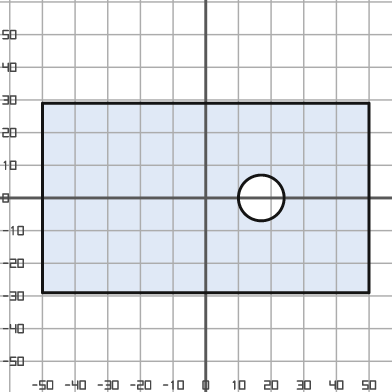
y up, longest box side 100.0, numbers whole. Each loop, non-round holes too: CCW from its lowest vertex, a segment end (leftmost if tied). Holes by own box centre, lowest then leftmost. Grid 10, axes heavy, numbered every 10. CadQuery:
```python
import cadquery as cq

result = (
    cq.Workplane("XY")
    .moveTo(-50.0, -29.0)
    .lineTo(50.0, -29.0)
    .lineTo(50.0, 29.0)
    .lineTo(-50.0, 29.0)
    .close()
    .moveTo(17.0, 0.0)
    .circle(7.0)
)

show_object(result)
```